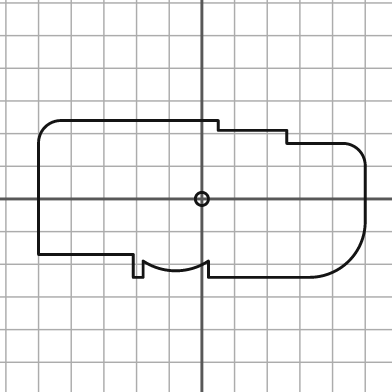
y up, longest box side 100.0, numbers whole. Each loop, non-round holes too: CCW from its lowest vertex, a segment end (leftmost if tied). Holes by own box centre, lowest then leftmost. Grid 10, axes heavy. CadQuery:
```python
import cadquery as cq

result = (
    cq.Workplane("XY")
    .moveTo(-21.0, -24.0)
    .lineTo(-18.0, -24.0)
    .lineTo(-18.0, -19.0)
    .threePointArc((-8.0, -22.0), (2.0, -19.0))
    .lineTo(2.0, -24.0)
    .lineTo(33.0, -24.0)
    .threePointArc((45.0, -19.0), (50.0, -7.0))
    .lineTo(50.0, 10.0)
    .threePointArc((48.0, 15.0), (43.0, 17.0))
    .lineTo(26.0, 17.0)
    .lineTo(26.0, 21.0)
    .lineTo(5.0, 21.0)
    .lineTo(5.0, 24.0)
    .lineTo(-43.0, 24.0)
    .threePointArc((-48.0, 22.0), (-50.0, 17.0))
    .lineTo(-50.0, -17.0)
    .lineTo(-21.0, -17.0)
    .close()
    .moveTo(0.0, 0.0)
    .circle(2.0)
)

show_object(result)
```